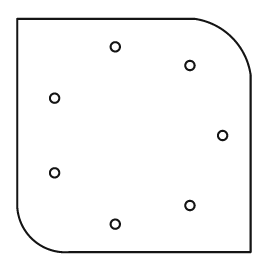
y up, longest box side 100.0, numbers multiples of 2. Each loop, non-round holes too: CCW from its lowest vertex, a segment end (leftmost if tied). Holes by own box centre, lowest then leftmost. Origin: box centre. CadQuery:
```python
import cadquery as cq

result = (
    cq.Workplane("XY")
    .moveTo(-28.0, -50.0)
    .lineTo(50.0, -50.0)
    .lineTo(50.0, 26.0)
    .threePointArc((42.0, 42.0), (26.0, 50.0))
    .lineTo(-50.0, 50.0)
    .lineTo(-50.0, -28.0)
    .threePointArc((-44.0, -44.0), (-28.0, -50.0))
    .close()
    .moveTo(-8.0, -38.0)
    .circle(2.0)
    .moveTo(24.0, -30.0)
    .circle(2.0)
    .moveTo(-34.0, -16.0)
    .circle(2.0)
    .moveTo(38.0, 0.0)
    .circle(2.0)
    .moveTo(-34.0, 16.0)
    .circle(2.0)
    .moveTo(24.0, 30.0)
    .circle(2.0)
    .moveTo(-8.0, 38.0)
    .circle(2.0)
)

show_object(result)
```